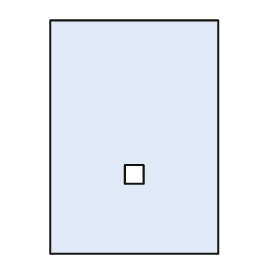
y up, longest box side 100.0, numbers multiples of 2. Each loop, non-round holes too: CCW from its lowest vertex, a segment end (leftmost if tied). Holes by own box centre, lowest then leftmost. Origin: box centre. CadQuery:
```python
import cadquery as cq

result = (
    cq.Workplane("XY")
    .moveTo(-36.0, -50.0)
    .lineTo(36.0, -50.0)
    .lineTo(36.0, 50.0)
    .lineTo(-36.0, 50.0)
    .close()
    .moveTo(-4.0, -20.0)
    .lineTo(4.0, -20.0)
    .lineTo(4.0, -12.0)
    .lineTo(-4.0, -12.0)
    .close()
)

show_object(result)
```